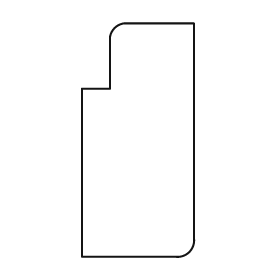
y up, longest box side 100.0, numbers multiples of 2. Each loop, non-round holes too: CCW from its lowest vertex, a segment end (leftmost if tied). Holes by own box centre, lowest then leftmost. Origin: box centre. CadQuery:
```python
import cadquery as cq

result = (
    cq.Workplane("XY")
    .moveTo(-24.0, -50.0)
    .lineTo(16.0, -50.0)
    .threePointArc((22.0, -48.0), (24.0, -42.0))
    .lineTo(24.0, 50.0)
    .lineTo(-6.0, 50.0)
    .threePointArc((-10.0, 48.0), (-12.0, 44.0))
    .lineTo(-12.0, 22.0)
    .lineTo(-24.0, 22.0)
    .close()
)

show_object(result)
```